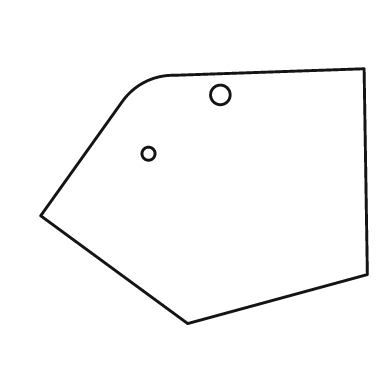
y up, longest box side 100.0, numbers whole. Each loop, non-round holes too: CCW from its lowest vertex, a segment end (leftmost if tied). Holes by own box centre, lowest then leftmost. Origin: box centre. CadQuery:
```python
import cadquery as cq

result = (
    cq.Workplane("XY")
    .moveTo(-5.0, -39.0)
    .lineTo(50.0, -24.0)
    .lineTo(49.0, 39.0)
    .lineTo(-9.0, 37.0)
    .threePointArc((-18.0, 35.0), (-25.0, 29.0))
    .lineTo(-50.0, -6.0)
    .close()
    .moveTo(-17.0, 13.0)
    .circle(2.0)
    .moveTo(5.0, 31.0)
    .circle(3.0)
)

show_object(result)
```